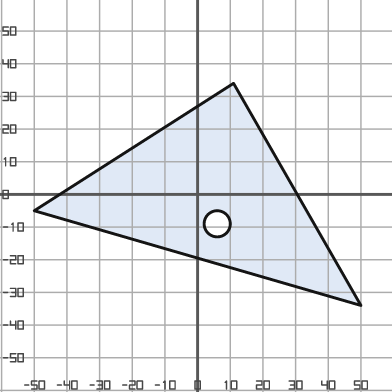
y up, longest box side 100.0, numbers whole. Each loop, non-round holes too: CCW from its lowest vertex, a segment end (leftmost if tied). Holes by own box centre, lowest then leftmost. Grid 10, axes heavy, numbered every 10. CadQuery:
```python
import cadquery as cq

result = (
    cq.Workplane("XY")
    .moveTo(50.0, -34.0)
    .lineTo(11.0, 34.0)
    .lineTo(-50.0, -5.0)
    .close()
    .moveTo(6.0, -9.0)
    .circle(4.0)
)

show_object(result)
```